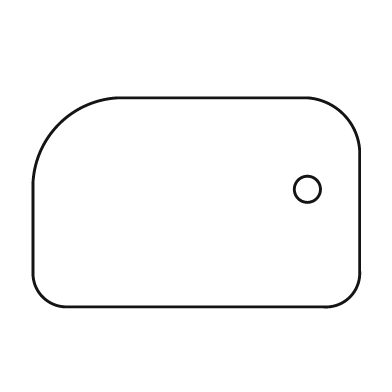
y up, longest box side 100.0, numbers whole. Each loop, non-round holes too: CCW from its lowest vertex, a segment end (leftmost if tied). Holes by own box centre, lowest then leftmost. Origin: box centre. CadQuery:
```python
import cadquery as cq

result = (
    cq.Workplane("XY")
    .moveTo(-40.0, -32.0)
    .lineTo(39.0, -32.0)
    .threePointArc((47.0, -29.0), (50.0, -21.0))
    .lineTo(50.0, 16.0)
    .threePointArc((45.0, 27.0), (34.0, 32.0))
    .lineTo(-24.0, 32.0)
    .threePointArc((-42.0, 24.0), (-50.0, 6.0))
    .lineTo(-50.0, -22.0)
    .threePointArc((-47.0, -29.0), (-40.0, -32.0))
    .close()
    .moveTo(34.0, 4.0)
    .circle(4.0)
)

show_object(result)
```